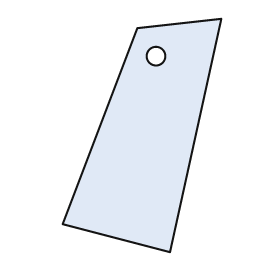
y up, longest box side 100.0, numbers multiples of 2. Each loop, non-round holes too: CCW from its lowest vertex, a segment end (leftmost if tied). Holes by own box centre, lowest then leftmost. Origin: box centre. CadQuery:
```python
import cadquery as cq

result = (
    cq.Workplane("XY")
    .moveTo(12.0, -50.0)
    .lineTo(34.0, 50.0)
    .lineTo(-2.0, 46.0)
    .lineTo(-34.0, -38.0)
    .close()
    .moveTo(6.0, 34.0)
    .circle(4.0)
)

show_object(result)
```